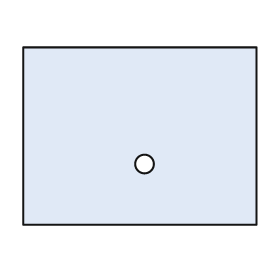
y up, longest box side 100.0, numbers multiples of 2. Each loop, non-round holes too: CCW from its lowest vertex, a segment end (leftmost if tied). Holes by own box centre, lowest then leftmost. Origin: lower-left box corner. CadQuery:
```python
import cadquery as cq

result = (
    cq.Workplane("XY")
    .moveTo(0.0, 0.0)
    .lineTo(100.0, 0.0)
    .lineTo(100.0, 76.0)
    .lineTo(0.0, 76.0)
    .close()
    .moveTo(52.0, 26.0)
    .circle(4.0)
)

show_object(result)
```